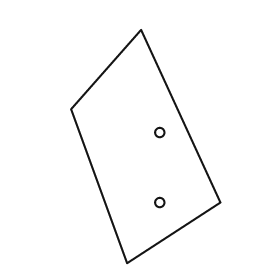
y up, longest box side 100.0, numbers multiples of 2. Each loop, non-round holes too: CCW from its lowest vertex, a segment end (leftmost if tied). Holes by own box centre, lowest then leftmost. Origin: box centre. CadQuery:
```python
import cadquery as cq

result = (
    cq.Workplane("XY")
    .moveTo(-8.0, -50.0)
    .lineTo(32.0, -24.0)
    .lineTo(-2.0, 50.0)
    .lineTo(-32.0, 16.0)
    .close()
    .moveTo(6.0, -24.0)
    .circle(2.0)
    .moveTo(6.0, 6.0)
    .circle(2.0)
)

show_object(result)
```